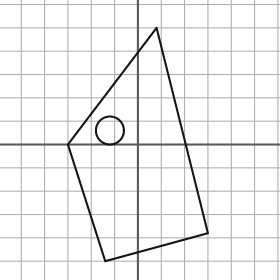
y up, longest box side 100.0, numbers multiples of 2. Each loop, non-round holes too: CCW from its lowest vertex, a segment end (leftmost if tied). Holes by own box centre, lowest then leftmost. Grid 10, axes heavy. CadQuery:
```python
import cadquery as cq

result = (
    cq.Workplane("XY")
    .moveTo(-14.0, -50.0)
    .lineTo(30.0, -38.0)
    .lineTo(8.0, 50.0)
    .lineTo(-30.0, 0.0)
    .close()
    .moveTo(-12.0, 6.0)
    .circle(6.0)
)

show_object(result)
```